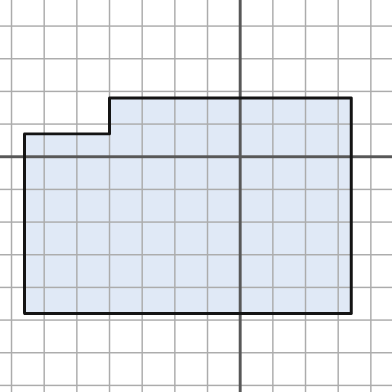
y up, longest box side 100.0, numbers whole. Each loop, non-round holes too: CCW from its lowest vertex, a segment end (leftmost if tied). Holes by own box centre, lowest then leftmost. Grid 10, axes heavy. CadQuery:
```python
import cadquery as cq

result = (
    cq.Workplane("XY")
    .moveTo(-66.0, -48.0)
    .lineTo(34.0, -48.0)
    .lineTo(34.0, 18.0)
    .lineTo(-40.0, 18.0)
    .lineTo(-40.0, 7.0)
    .lineTo(-66.0, 7.0)
    .close()
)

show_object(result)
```